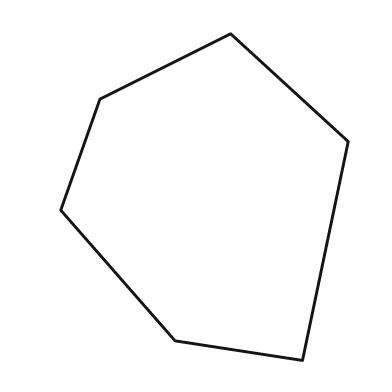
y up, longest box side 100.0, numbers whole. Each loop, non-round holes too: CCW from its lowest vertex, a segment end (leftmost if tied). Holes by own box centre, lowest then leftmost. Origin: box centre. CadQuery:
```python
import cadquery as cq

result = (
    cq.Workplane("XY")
    .moveTo(30.0, -50.0)
    .lineTo(44.0, 17.0)
    .lineTo(8.0, 50.0)
    .lineTo(-32.0, 30.0)
    .lineTo(-44.0, -4.0)
    .lineTo(-9.0, -44.0)
    .close()
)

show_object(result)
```